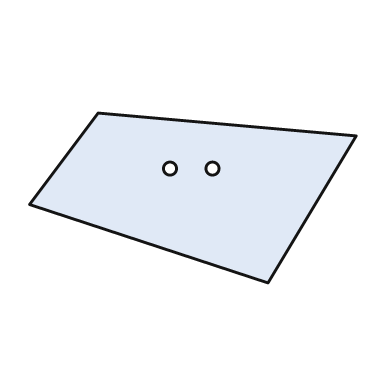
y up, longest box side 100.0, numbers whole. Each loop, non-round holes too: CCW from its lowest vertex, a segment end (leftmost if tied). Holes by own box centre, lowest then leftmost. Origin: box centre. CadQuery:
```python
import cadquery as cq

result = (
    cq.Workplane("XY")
    .moveTo(23.0, -26.0)
    .lineTo(50.0, 19.0)
    .lineTo(-29.0, 26.0)
    .lineTo(-50.0, -2.0)
    .close()
    .moveTo(-7.0, 9.0)
    .circle(2.0)
    .moveTo(6.0, 9.0)
    .circle(2.0)
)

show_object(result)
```